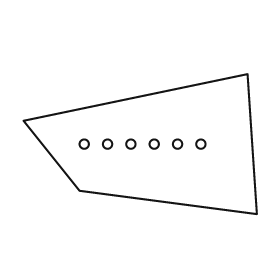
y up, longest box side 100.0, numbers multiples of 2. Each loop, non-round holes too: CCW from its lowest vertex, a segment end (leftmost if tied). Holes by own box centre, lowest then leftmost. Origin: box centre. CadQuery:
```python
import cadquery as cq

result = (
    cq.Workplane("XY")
    .moveTo(50.0, -30.0)
    .lineTo(46.0, 30.0)
    .lineTo(-50.0, 10.0)
    .lineTo(-26.0, -20.0)
    .close()
    .moveTo(-24.0, 0.0)
    .circle(2.0)
    .moveTo(-14.0, 0.0)
    .circle(2.0)
    .moveTo(-4.0, 0.0)
    .circle(2.0)
    .moveTo(6.0, 0.0)
    .circle(2.0)
    .moveTo(16.0, 0.0)
    .circle(2.0)
    .moveTo(26.0, 0.0)
    .circle(2.0)
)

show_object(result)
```